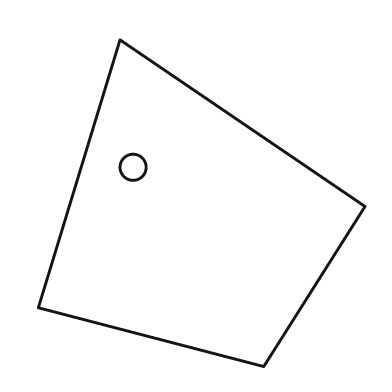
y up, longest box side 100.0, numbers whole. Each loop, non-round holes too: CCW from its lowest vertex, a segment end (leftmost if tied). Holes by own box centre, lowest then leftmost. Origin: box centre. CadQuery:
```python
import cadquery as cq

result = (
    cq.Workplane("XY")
    .moveTo(19.0, -50.0)
    .lineTo(50.0, -1.0)
    .lineTo(-25.0, 50.0)
    .lineTo(-50.0, -32.0)
    .close()
    .moveTo(-21.0, 11.0)
    .circle(4.0)
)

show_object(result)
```